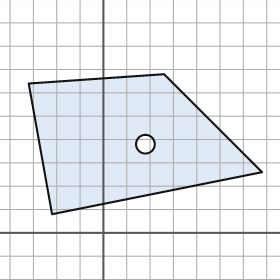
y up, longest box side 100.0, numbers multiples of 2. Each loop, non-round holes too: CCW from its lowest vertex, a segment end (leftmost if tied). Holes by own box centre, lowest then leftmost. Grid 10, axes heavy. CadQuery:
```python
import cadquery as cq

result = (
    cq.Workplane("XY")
    .moveTo(-22.0, 8.0)
    .lineTo(68.0, 26.0)
    .lineTo(26.0, 68.0)
    .lineTo(-32.0, 64.0)
    .close()
    .moveTo(18.0, 38.0)
    .circle(4.0)
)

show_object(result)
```